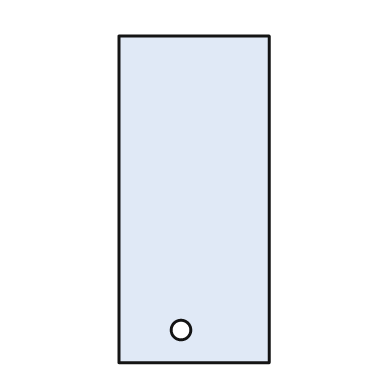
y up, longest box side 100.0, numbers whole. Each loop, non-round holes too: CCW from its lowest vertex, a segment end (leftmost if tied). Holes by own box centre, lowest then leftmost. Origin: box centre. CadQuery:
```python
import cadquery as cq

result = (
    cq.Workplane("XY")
    .moveTo(-23.0, -50.0)
    .lineTo(23.0, -50.0)
    .lineTo(23.0, 50.0)
    .lineTo(-23.0, 50.0)
    .close()
    .moveTo(-4.0, -40.0)
    .circle(3.0)
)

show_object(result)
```